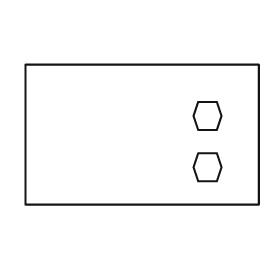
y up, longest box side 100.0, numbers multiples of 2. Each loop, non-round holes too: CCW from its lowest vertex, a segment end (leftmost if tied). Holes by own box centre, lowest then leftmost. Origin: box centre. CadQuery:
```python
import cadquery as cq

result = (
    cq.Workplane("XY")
    .moveTo(-50.0, -30.0)
    .lineTo(50.0, -30.0)
    .lineTo(50.0, 30.0)
    .lineTo(-50.0, 30.0)
    .close()
    .moveTo(24.0, -20.0)
    .lineTo(32.0, -20.0)
    .lineTo(34.0, -14.0)
    .lineTo(32.0, -8.0)
    .lineTo(24.0, -8.0)
    .lineTo(22.0, -14.0)
    .close()
    .moveTo(24.0, 2.0)
    .lineTo(32.0, 2.0)
    .lineTo(34.0, 8.0)
    .lineTo(32.0, 14.0)
    .lineTo(24.0, 14.0)
    .lineTo(22.0, 8.0)
    .close()
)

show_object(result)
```